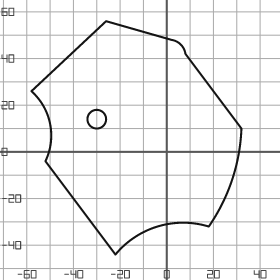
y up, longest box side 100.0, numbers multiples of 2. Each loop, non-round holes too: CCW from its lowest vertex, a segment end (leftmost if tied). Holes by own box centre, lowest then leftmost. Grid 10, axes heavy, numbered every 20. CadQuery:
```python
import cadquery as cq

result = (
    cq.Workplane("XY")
    .moveTo(-22.0, -44.0)
    .threePointArc((-4.0, -32.0), (18.0, -32.0))
    .threePointArc((28.0, -12.0), (32.0, 10.0))
    .lineTo(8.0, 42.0)
    .threePointArc((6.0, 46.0), (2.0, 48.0))
    .lineTo(-26.0, 56.0)
    .lineTo(-58.0, 26.0)
    .threePointArc((-50.0, 12.0), (-52.0, -4.0))
    .close()
    .moveTo(-30.0, 14.0)
    .circle(4.0)
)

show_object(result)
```